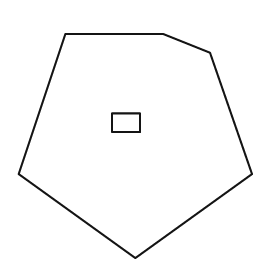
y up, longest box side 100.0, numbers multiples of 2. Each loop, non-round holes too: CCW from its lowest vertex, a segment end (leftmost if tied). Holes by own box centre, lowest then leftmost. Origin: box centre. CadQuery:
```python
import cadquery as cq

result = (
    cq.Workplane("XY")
    .moveTo(0.0, -48.0)
    .lineTo(50.0, -12.0)
    .lineTo(32.0, 40.0)
    .lineTo(12.0, 48.0)
    .lineTo(-30.0, 48.0)
    .lineTo(-50.0, -12.0)
    .close()
    .moveTo(-10.0, 6.0)
    .lineTo(2.0, 6.0)
    .lineTo(2.0, 14.0)
    .lineTo(-10.0, 14.0)
    .close()
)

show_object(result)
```